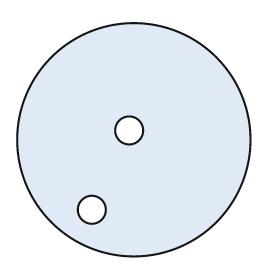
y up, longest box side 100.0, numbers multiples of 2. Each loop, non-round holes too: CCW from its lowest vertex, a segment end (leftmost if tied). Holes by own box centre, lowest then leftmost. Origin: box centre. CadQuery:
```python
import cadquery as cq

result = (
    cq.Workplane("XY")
    .moveTo(0.0, 0.0)
    .circle(50.0)
    .moveTo(-18.0, -30.0)
    .circle(6.0)
    .moveTo(-2.0, 4.0)
    .circle(6.0)
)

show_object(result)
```